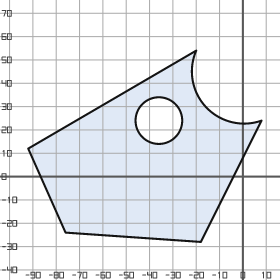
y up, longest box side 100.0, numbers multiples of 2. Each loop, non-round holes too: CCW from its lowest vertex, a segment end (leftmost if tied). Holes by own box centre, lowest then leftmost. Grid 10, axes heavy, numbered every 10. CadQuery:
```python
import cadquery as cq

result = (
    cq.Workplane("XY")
    .moveTo(-18.0, -28.0)
    .lineTo(8.0, 24.0)
    .threePointArc((-16.0, 30.0), (-20.0, 54.0))
    .lineTo(-92.0, 12.0)
    .lineTo(-76.0, -24.0)
    .close()
    .moveTo(-36.0, 24.0)
    .circle(10.0)
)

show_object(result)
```